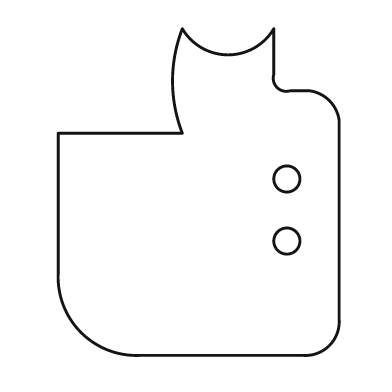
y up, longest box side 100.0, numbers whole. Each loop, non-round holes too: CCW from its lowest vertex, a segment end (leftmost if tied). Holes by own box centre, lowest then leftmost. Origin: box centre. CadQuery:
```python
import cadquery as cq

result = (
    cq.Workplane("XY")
    .moveTo(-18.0, -50.0)
    .lineTo(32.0, -50.0)
    .threePointArc((40.0, -47.0), (43.0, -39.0))
    .lineTo(43.0, 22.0)
    .threePointArc((40.0, 28.0), (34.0, 31.0))
    .lineTo(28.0, 31.0)
    .threePointArc((24.0, 32.0), (23.0, 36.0))
    .lineTo(23.0, 50.0)
    .threePointArc((9.0, 42.0), (-5.0, 50.0))
    .threePointArc((-8.0, 34.0), (-5.0, 18.0))
    .lineTo(-43.0, 18.0)
    .lineTo(-43.0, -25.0)
    .threePointArc((-36.0, -43.0), (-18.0, -50.0))
    .close()
    .moveTo(27.0, -15.0)
    .circle(4.0)
    .moveTo(27.0, 4.0)
    .circle(4.0)
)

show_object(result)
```